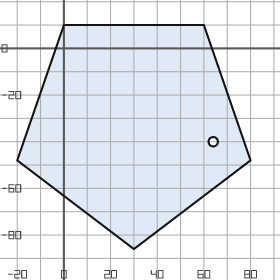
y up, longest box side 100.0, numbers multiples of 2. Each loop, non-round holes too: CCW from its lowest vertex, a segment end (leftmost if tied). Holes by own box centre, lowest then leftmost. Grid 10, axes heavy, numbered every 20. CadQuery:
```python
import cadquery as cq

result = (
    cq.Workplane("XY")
    .moveTo(30.0, -86.0)
    .lineTo(80.0, -48.0)
    .lineTo(60.0, 10.0)
    .lineTo(0.0, 10.0)
    .lineTo(-20.0, -48.0)
    .close()
    .moveTo(64.0, -40.0)
    .circle(2.0)
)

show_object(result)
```